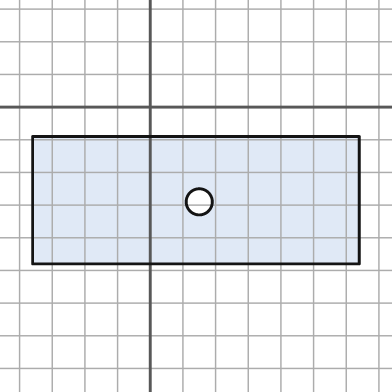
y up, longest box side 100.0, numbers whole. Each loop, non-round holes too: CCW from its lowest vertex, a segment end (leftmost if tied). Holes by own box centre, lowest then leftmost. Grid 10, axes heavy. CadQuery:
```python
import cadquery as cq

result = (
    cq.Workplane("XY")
    .moveTo(-36.0, -48.0)
    .lineTo(64.0, -48.0)
    .lineTo(64.0, -9.0)
    .lineTo(-36.0, -9.0)
    .close()
    .moveTo(15.0, -29.0)
    .circle(4.0)
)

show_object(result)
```